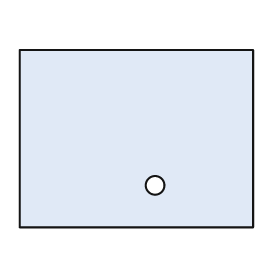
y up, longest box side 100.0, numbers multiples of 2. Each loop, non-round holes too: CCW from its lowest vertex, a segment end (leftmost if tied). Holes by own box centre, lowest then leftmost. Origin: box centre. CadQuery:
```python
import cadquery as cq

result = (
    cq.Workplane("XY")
    .moveTo(-50.0, -38.0)
    .lineTo(50.0, -38.0)
    .lineTo(50.0, 38.0)
    .lineTo(-50.0, 38.0)
    .close()
    .moveTo(8.0, -20.0)
    .circle(4.0)
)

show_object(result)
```